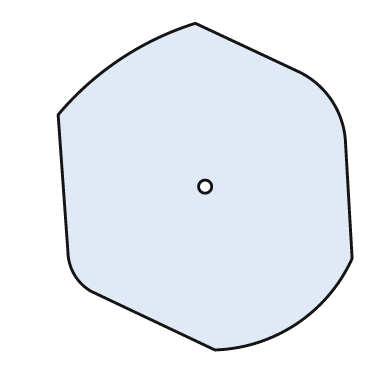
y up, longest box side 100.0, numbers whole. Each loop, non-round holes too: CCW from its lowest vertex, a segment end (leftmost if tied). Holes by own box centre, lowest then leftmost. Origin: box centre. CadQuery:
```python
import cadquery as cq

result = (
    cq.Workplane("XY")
    .moveTo(3.0, -50.0)
    .threePointArc((28.0, -42.0), (45.0, -22.0))
    .lineTo(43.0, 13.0)
    .threePointArc((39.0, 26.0), (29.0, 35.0))
    .lineTo(-3.0, 50.0)
    .threePointArc((-26.0, 39.0), (-45.0, 22.0))
    .lineTo(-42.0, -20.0)
    .threePointArc((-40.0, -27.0), (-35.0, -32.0))
    .close()
    .moveTo(0.0, 0.0)
    .circle(2.0)
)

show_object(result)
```